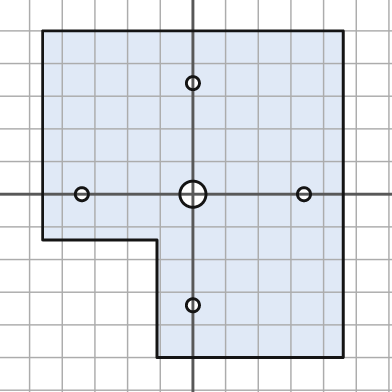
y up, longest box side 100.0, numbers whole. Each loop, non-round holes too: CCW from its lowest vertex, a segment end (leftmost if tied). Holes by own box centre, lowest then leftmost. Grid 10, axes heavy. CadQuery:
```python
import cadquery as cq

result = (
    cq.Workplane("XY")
    .moveTo(-11.0, -50.0)
    .lineTo(46.0, -50.0)
    .lineTo(46.0, 50.0)
    .lineTo(-46.0, 50.0)
    .lineTo(-46.0, -14.0)
    .lineTo(-11.0, -14.0)
    .close()
    .moveTo(0.0, -34.0)
    .circle(2.0)
    .moveTo(-34.0, 0.0)
    .circle(2.0)
    .moveTo(0.0, 0.0)
    .circle(4.0)
    .moveTo(34.0, 0.0)
    .circle(2.0)
    .moveTo(0.0, 34.0)
    .circle(2.0)
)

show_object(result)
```